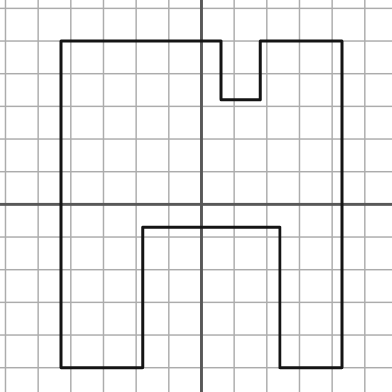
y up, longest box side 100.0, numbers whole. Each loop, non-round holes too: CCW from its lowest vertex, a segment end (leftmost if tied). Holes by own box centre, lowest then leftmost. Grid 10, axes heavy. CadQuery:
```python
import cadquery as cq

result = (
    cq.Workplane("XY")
    .moveTo(-43.0, -50.0)
    .lineTo(-18.0, -50.0)
    .lineTo(-18.0, -7.0)
    .lineTo(24.0, -7.0)
    .lineTo(24.0, -50.0)
    .lineTo(43.0, -50.0)
    .lineTo(43.0, 50.0)
    .lineTo(18.0, 50.0)
    .lineTo(18.0, 32.0)
    .lineTo(6.0, 32.0)
    .lineTo(6.0, 50.0)
    .lineTo(-43.0, 50.0)
    .close()
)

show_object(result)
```